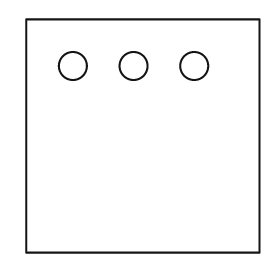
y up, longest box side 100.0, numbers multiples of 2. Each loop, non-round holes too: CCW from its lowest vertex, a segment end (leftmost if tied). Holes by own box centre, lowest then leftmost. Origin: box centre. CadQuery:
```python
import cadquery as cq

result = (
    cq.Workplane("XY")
    .moveTo(-50.0, -50.0)
    .lineTo(50.0, -50.0)
    .lineTo(50.0, 50.0)
    .lineTo(-50.0, 50.0)
    .close()
    .moveTo(-30.0, 30.0)
    .circle(6.0)
    .moveTo(-4.0, 30.0)
    .circle(6.0)
    .moveTo(22.0, 30.0)
    .circle(6.0)
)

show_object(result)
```